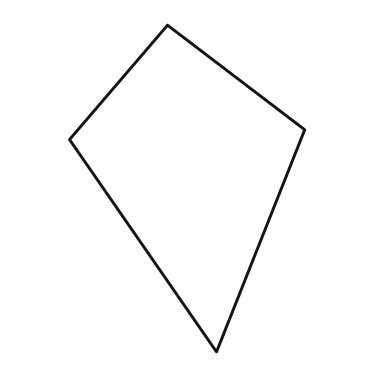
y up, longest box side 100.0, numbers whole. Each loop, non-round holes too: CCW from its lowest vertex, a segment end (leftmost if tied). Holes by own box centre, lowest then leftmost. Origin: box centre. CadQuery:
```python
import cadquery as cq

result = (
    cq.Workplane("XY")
    .moveTo(9.0, -50.0)
    .lineTo(36.0, 18.0)
    .lineTo(-6.0, 50.0)
    .lineTo(-36.0, 15.0)
    .close()
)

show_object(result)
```